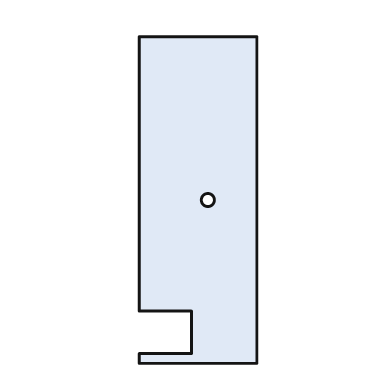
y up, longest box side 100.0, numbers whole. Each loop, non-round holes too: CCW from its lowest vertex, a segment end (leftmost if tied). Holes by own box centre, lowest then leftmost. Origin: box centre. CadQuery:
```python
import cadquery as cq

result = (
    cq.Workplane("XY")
    .moveTo(-18.0, -50.0)
    .lineTo(18.0, -50.0)
    .lineTo(18.0, 50.0)
    .lineTo(-18.0, 50.0)
    .lineTo(-18.0, -34.0)
    .lineTo(-2.0, -34.0)
    .lineTo(-2.0, -47.0)
    .lineTo(-18.0, -47.0)
    .close()
    .moveTo(3.0, 0.0)
    .circle(2.0)
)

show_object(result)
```